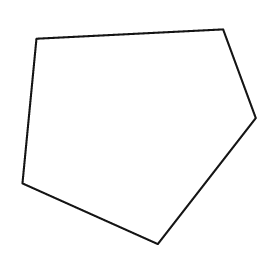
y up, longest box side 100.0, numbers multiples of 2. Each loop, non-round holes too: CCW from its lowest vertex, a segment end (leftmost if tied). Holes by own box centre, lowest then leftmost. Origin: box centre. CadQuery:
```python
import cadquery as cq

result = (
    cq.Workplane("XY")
    .moveTo(8.0, -46.0)
    .lineTo(50.0, 8.0)
    .lineTo(36.0, 46.0)
    .lineTo(-44.0, 42.0)
    .lineTo(-50.0, -20.0)
    .close()
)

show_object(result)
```